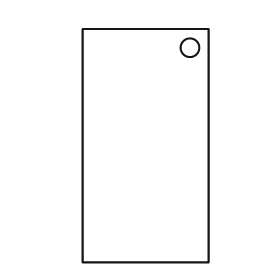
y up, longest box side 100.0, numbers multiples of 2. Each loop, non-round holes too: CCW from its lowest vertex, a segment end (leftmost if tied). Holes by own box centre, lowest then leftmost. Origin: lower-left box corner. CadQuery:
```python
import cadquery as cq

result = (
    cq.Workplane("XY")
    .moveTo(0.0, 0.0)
    .lineTo(54.0, 0.0)
    .lineTo(54.0, 100.0)
    .lineTo(0.0, 100.0)
    .close()
    .moveTo(46.0, 92.0)
    .circle(4.0)
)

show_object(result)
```